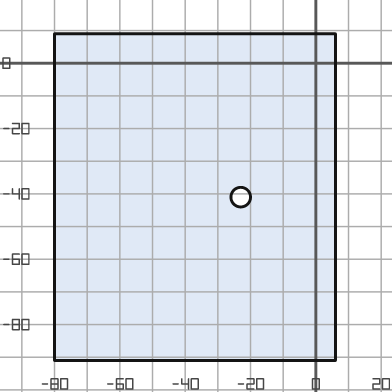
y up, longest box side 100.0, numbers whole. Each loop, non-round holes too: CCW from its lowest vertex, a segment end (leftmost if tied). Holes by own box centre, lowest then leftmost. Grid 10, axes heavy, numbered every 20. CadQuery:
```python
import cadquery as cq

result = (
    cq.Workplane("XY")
    .moveTo(-80.0, -91.0)
    .lineTo(6.0, -91.0)
    .lineTo(6.0, 9.0)
    .lineTo(-80.0, 9.0)
    .close()
    .moveTo(-23.0, -41.0)
    .circle(3.0)
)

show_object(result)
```